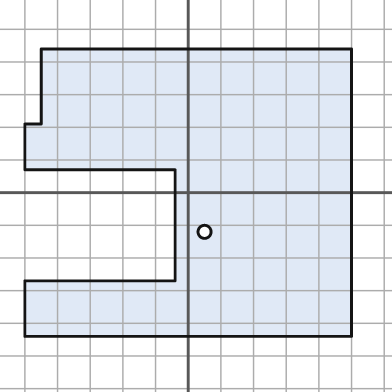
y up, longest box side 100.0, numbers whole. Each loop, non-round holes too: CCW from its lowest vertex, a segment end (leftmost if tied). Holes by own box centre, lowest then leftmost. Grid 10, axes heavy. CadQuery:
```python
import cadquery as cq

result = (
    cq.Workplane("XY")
    .moveTo(-50.0, -44.0)
    .lineTo(50.0, -44.0)
    .lineTo(50.0, 44.0)
    .lineTo(-45.0, 44.0)
    .lineTo(-45.0, 21.0)
    .lineTo(-50.0, 21.0)
    .lineTo(-50.0, 7.0)
    .lineTo(-4.0, 7.0)
    .lineTo(-4.0, -27.0)
    .lineTo(-50.0, -27.0)
    .close()
    .moveTo(5.0, -12.0)
    .circle(2.0)
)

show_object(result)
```